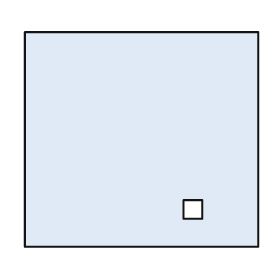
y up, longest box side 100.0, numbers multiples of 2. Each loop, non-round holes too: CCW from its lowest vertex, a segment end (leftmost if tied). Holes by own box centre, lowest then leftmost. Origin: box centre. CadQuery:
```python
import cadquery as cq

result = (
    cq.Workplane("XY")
    .moveTo(-50.0, -46.0)
    .lineTo(50.0, -46.0)
    .lineTo(50.0, 46.0)
    .lineTo(-50.0, 46.0)
    .close()
    .moveTo(18.0, -34.0)
    .lineTo(26.0, -34.0)
    .lineTo(26.0, -26.0)
    .lineTo(18.0, -26.0)
    .close()
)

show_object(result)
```